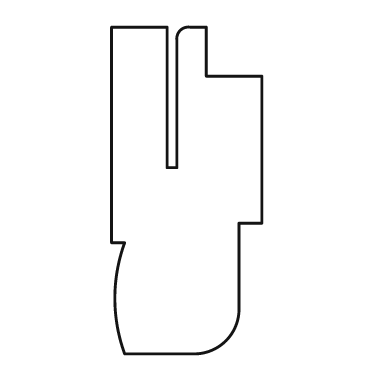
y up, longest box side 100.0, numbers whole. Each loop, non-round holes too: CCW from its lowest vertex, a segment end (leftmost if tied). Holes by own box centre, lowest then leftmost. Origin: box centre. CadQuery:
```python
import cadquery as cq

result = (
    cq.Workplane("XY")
    .moveTo(-19.0, -50.0)
    .lineTo(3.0, -50.0)
    .threePointArc((12.0, -46.0), (16.0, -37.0))
    .lineTo(16.0, -10.0)
    .lineTo(23.0, -10.0)
    .lineTo(23.0, 35.0)
    .lineTo(6.0, 35.0)
    .lineTo(6.0, 50.0)
    .lineTo(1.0, 50.0)
    .threePointArc((-2.0, 49.0), (-3.0, 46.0))
    .lineTo(-3.0, 7.0)
    .lineTo(-6.0, 7.0)
    .lineTo(-6.0, 50.0)
    .lineTo(-23.0, 50.0)
    .lineTo(-23.0, -16.0)
    .lineTo(-19.0, -16.0)
    .threePointArc((-22.0, -33.0), (-19.0, -50.0))
    .close()
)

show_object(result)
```